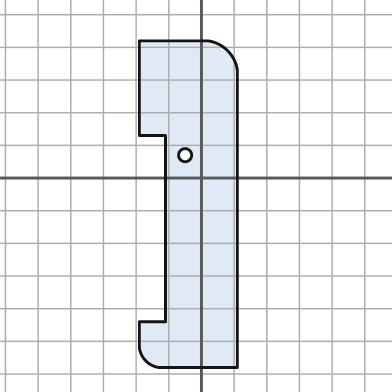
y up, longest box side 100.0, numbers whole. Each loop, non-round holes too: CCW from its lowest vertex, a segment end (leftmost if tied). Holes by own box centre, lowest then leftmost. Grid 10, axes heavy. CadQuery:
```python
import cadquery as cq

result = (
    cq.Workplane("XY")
    .moveTo(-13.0, -58.0)
    .lineTo(11.0, -58.0)
    .lineTo(11.0, 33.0)
    .threePointArc((8.0, 39.0), (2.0, 42.0))
    .lineTo(-19.0, 42.0)
    .lineTo(-19.0, 13.0)
    .lineTo(-11.0, 13.0)
    .lineTo(-11.0, -44.0)
    .lineTo(-19.0, -44.0)
    .lineTo(-19.0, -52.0)
    .threePointArc((-17.0, -56.0), (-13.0, -58.0))
    .close()
    .moveTo(-5.0, 7.0)
    .circle(2.0)
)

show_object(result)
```